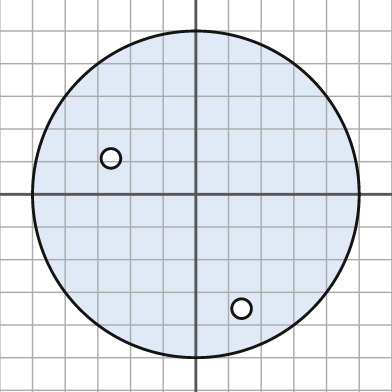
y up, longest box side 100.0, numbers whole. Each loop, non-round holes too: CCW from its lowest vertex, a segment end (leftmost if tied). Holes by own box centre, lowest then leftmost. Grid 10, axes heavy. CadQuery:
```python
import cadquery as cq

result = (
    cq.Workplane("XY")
    .moveTo(0.0, 0.0)
    .circle(50.0)
    .moveTo(14.0, -35.0)
    .circle(3.0)
    .moveTo(-26.0, 11.0)
    .circle(3.0)
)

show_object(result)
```